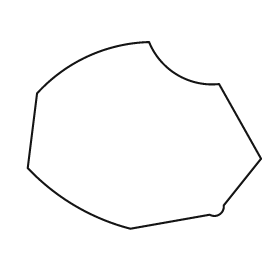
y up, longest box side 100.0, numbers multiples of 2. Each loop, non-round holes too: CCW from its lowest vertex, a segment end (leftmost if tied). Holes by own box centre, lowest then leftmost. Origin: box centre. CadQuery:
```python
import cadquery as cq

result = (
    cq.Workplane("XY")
    .moveTo(-6.0, -40.0)
    .lineTo(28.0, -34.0)
    .threePointArc((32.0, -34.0), (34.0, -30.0))
    .lineTo(50.0, -10.0)
    .lineTo(32.0, 22.0)
    .threePointArc((14.0, 26.0), (2.0, 40.0))
    .threePointArc((-24.0, 34.0), (-46.0, 18.0))
    .lineTo(-50.0, -14.0)
    .threePointArc((-30.0, -30.0), (-6.0, -40.0))
    .close()
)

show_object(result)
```